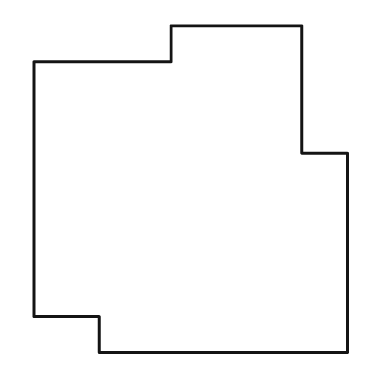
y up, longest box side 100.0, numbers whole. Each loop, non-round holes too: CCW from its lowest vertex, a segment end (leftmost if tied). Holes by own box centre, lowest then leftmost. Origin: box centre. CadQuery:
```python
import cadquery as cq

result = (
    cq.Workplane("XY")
    .moveTo(-28.0, -50.0)
    .lineTo(48.0, -50.0)
    .lineTo(48.0, 11.0)
    .lineTo(34.0, 11.0)
    .lineTo(34.0, 50.0)
    .lineTo(-6.0, 50.0)
    .lineTo(-6.0, 39.0)
    .lineTo(-48.0, 39.0)
    .lineTo(-48.0, -39.0)
    .lineTo(-28.0, -39.0)
    .close()
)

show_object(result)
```